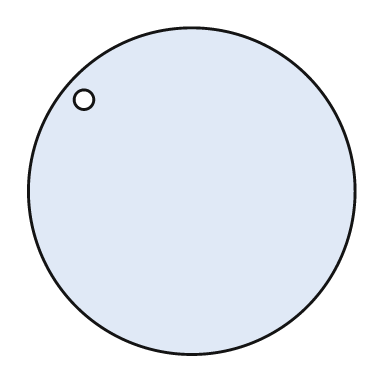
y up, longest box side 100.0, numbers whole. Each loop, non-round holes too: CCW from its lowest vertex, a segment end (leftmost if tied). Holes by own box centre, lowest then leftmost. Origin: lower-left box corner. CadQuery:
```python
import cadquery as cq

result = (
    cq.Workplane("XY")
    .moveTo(50.0, 50.0)
    .circle(50.0)
    .moveTo(17.0, 78.0)
    .circle(3.0)
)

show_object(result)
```